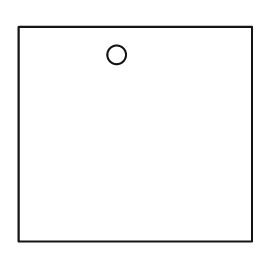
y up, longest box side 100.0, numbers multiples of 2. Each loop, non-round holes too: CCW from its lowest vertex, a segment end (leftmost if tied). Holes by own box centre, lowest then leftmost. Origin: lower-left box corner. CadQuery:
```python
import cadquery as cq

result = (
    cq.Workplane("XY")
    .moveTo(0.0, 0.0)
    .lineTo(100.0, 0.0)
    .lineTo(100.0, 92.0)
    .lineTo(0.0, 92.0)
    .close()
    .moveTo(42.0, 80.0)
    .circle(4.0)
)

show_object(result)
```